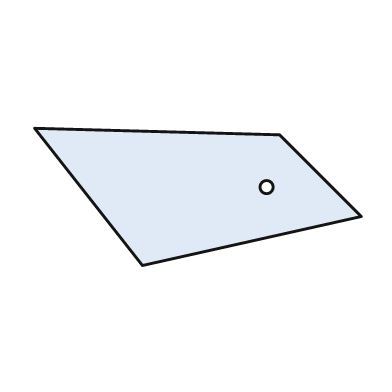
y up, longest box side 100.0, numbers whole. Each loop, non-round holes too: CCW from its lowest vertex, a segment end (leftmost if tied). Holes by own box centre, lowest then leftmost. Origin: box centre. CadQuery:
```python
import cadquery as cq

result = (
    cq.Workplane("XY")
    .moveTo(-17.0, -21.0)
    .lineTo(50.0, -6.0)
    .lineTo(25.0, 19.0)
    .lineTo(-50.0, 21.0)
    .close()
    .moveTo(21.0, 3.0)
    .circle(2.0)
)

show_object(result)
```